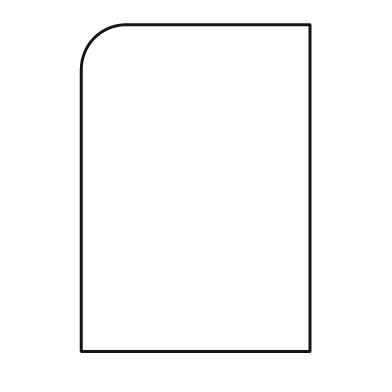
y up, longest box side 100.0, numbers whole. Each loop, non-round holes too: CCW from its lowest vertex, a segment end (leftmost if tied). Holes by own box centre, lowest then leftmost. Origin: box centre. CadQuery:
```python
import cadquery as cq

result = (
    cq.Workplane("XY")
    .moveTo(-35.0, -50.0)
    .lineTo(35.0, -50.0)
    .lineTo(35.0, 50.0)
    .lineTo(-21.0, 50.0)
    .threePointArc((-31.0, 46.0), (-35.0, 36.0))
    .close()
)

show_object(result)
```